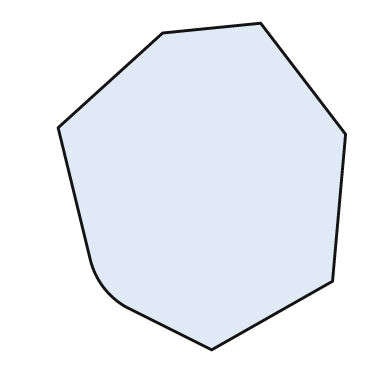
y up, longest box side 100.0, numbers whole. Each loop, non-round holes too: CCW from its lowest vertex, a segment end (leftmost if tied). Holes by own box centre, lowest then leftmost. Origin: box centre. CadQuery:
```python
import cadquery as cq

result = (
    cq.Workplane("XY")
    .moveTo(3.0, -50.0)
    .lineTo(40.0, -29.0)
    .lineTo(44.0, 16.0)
    .lineTo(18.0, 50.0)
    .lineTo(-12.0, 47.0)
    .lineTo(-44.0, 18.0)
    .lineTo(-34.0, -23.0)
    .threePointArc((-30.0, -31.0), (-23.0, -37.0))
    .close()
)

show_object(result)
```